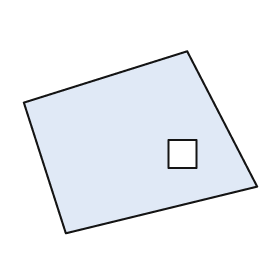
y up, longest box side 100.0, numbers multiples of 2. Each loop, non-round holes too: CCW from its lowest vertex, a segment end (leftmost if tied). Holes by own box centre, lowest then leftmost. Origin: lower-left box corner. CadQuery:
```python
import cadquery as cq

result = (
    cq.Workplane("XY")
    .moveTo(18.0, 0.0)
    .lineTo(100.0, 20.0)
    .lineTo(70.0, 78.0)
    .lineTo(0.0, 56.0)
    .close()
    .moveTo(62.0, 28.0)
    .lineTo(74.0, 28.0)
    .lineTo(74.0, 40.0)
    .lineTo(62.0, 40.0)
    .close()
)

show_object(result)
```